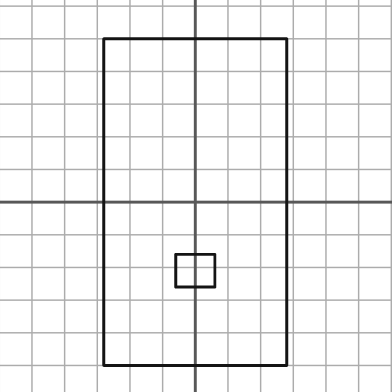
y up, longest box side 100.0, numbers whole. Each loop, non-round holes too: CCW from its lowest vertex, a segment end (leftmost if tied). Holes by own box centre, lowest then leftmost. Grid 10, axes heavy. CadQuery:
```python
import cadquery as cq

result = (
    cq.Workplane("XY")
    .moveTo(-28.0, -50.0)
    .lineTo(28.0, -50.0)
    .lineTo(28.0, 50.0)
    .lineTo(-28.0, 50.0)
    .close()
    .moveTo(-6.0, -26.0)
    .lineTo(6.0, -26.0)
    .lineTo(6.0, -16.0)
    .lineTo(-6.0, -16.0)
    .close()
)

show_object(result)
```